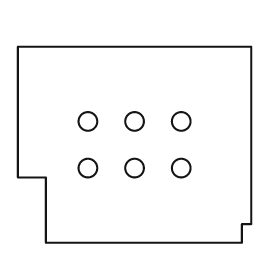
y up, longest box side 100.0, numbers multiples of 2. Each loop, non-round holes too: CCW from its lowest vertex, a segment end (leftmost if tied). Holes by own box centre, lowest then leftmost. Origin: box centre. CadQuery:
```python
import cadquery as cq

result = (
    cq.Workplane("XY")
    .moveTo(-38.0, -42.0)
    .lineTo(46.0, -42.0)
    .lineTo(46.0, -34.0)
    .lineTo(50.0, -34.0)
    .lineTo(50.0, 42.0)
    .lineTo(-50.0, 42.0)
    .lineTo(-50.0, -14.0)
    .lineTo(-38.0, -14.0)
    .close()
    .moveTo(-20.0, -10.0)
    .circle(4.0)
    .moveTo(0.0, -10.0)
    .circle(4.0)
    .moveTo(20.0, -10.0)
    .circle(4.0)
    .moveTo(-20.0, 10.0)
    .circle(4.0)
    .moveTo(0.0, 10.0)
    .circle(4.0)
    .moveTo(20.0, 10.0)
    .circle(4.0)
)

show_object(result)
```